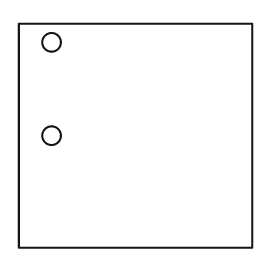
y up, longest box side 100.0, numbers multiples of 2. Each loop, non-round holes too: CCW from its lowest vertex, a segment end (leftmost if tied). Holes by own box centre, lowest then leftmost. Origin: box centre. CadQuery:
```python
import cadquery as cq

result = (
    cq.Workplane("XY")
    .moveTo(-50.0, -48.0)
    .lineTo(50.0, -48.0)
    .lineTo(50.0, 48.0)
    .lineTo(-50.0, 48.0)
    .close()
    .moveTo(-36.0, 0.0)
    .circle(4.0)
    .moveTo(-36.0, 40.0)
    .circle(4.0)
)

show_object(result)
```